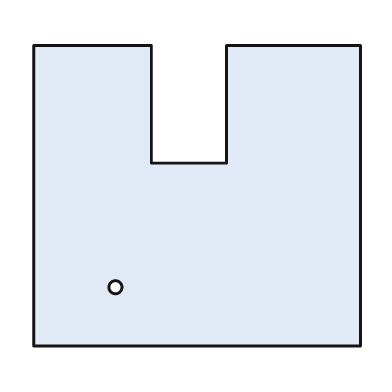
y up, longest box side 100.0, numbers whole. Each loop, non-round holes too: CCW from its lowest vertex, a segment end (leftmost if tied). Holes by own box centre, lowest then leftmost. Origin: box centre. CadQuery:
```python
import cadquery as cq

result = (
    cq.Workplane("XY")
    .moveTo(-50.0, -46.0)
    .lineTo(50.0, -46.0)
    .lineTo(50.0, 46.0)
    .lineTo(9.0, 46.0)
    .lineTo(9.0, 10.0)
    .lineTo(-14.0, 10.0)
    .lineTo(-14.0, 46.0)
    .lineTo(-50.0, 46.0)
    .close()
    .moveTo(-25.0, -28.0)
    .circle(2.0)
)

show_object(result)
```